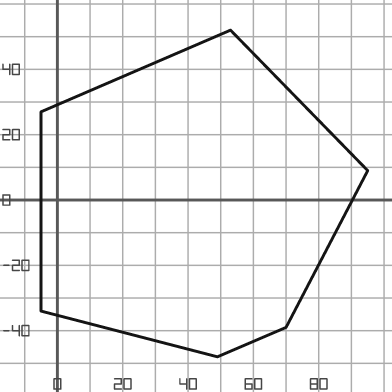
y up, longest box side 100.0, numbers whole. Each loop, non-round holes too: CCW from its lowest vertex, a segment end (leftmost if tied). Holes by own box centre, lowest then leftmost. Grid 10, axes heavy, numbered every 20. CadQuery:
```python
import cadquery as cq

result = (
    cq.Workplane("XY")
    .moveTo(49.0, -48.0)
    .lineTo(70.0, -39.0)
    .lineTo(95.0, 9.0)
    .lineTo(53.0, 52.0)
    .lineTo(-5.0, 27.0)
    .lineTo(-5.0, -34.0)
    .close()
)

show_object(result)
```